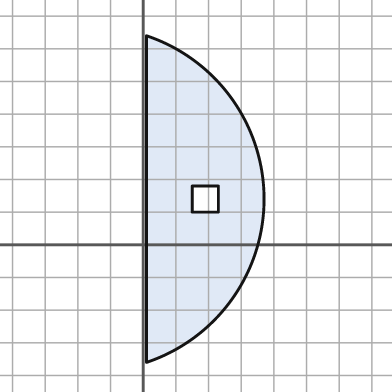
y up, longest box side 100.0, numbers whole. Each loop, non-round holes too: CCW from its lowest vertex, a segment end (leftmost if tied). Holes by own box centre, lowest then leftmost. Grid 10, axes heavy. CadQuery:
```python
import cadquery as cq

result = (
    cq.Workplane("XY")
    .moveTo(1.0, -36.0)
    .threePointArc((37.0, 14.0), (1.0, 64.0))
    .close()
    .moveTo(15.0, 10.0)
    .lineTo(23.0, 10.0)
    .lineTo(23.0, 18.0)
    .lineTo(15.0, 18.0)
    .close()
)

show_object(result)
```